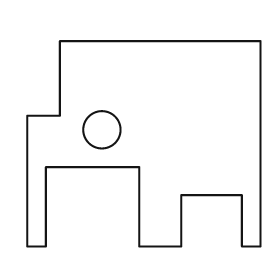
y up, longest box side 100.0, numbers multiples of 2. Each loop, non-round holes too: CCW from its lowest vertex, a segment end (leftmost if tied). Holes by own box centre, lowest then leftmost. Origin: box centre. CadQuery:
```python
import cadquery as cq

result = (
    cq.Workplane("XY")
    .moveTo(-50.0, -44.0)
    .lineTo(-42.0, -44.0)
    .lineTo(-42.0, -10.0)
    .lineTo(-2.0, -10.0)
    .lineTo(-2.0, -44.0)
    .lineTo(16.0, -44.0)
    .lineTo(16.0, -22.0)
    .lineTo(42.0, -22.0)
    .lineTo(42.0, -44.0)
    .lineTo(50.0, -44.0)
    .lineTo(50.0, 44.0)
    .lineTo(-36.0, 44.0)
    .lineTo(-36.0, 12.0)
    .lineTo(-50.0, 12.0)
    .close()
    .moveTo(-18.0, 6.0)
    .circle(8.0)
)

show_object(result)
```